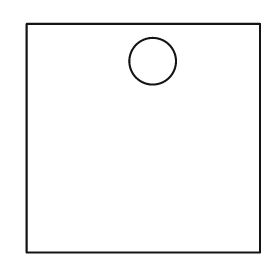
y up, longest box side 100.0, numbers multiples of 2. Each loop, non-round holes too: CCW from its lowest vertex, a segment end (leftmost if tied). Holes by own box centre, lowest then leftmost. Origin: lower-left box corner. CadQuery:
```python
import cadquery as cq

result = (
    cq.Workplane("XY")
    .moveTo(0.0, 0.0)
    .lineTo(100.0, 0.0)
    .lineTo(100.0, 98.0)
    .lineTo(0.0, 98.0)
    .close()
    .moveTo(54.0, 82.0)
    .circle(10.0)
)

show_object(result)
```